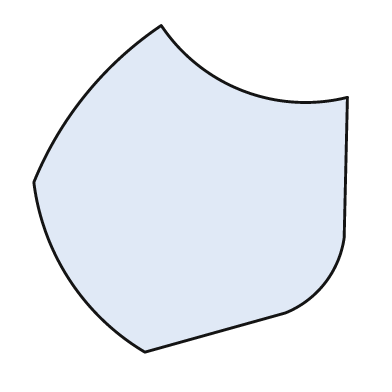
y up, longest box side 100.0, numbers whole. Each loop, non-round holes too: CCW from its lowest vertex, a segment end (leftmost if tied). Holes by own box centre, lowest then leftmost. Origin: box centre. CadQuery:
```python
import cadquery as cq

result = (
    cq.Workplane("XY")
    .moveTo(-14.0, -50.0)
    .lineTo(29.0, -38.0)
    .threePointArc((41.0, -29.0), (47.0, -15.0))
    .lineTo(48.0, 28.0)
    .threePointArc((16.0, 30.0), (-9.0, 50.0))
    .threePointArc((-32.0, 29.0), (-48.0, 2.0))
    .threePointArc((-37.0, -28.0), (-14.0, -50.0))
    .close()
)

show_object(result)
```